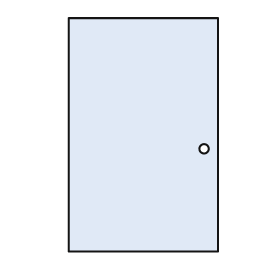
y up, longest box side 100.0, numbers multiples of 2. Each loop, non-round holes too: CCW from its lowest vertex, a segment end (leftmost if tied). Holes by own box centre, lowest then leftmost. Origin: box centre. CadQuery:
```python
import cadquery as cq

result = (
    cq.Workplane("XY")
    .moveTo(-32.0, -50.0)
    .lineTo(32.0, -50.0)
    .lineTo(32.0, 50.0)
    .lineTo(-32.0, 50.0)
    .close()
    .moveTo(26.0, -6.0)
    .circle(2.0)
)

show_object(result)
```